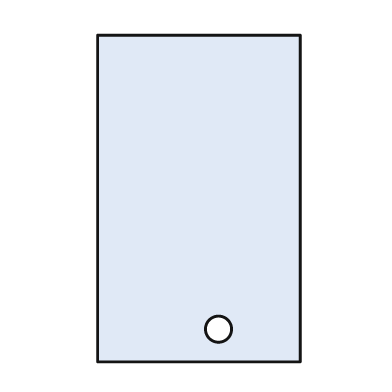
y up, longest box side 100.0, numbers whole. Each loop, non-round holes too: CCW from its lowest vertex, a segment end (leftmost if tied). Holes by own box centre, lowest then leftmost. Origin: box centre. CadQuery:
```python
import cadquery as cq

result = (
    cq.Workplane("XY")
    .moveTo(-31.0, -50.0)
    .lineTo(31.0, -50.0)
    .lineTo(31.0, 50.0)
    .lineTo(-31.0, 50.0)
    .close()
    .moveTo(6.0, -40.0)
    .circle(4.0)
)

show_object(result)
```